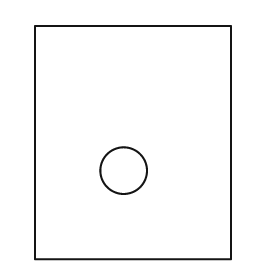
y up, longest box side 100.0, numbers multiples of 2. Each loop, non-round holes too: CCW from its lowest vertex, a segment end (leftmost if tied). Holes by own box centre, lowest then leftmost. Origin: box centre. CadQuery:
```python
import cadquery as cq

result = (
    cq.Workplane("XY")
    .moveTo(-42.0, -50.0)
    .lineTo(42.0, -50.0)
    .lineTo(42.0, 50.0)
    .lineTo(-42.0, 50.0)
    .close()
    .moveTo(-4.0, -12.0)
    .circle(10.0)
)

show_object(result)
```